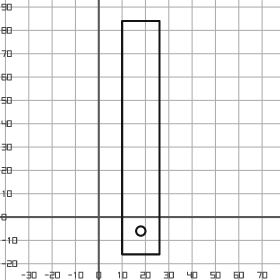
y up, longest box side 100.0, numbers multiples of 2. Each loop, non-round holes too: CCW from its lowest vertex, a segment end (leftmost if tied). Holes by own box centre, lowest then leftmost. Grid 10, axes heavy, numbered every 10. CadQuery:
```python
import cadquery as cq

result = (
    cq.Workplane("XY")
    .moveTo(10.0, -16.0)
    .lineTo(26.0, -16.0)
    .lineTo(26.0, 84.0)
    .lineTo(10.0, 84.0)
    .close()
    .moveTo(18.0, -6.0)
    .circle(2.0)
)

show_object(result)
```